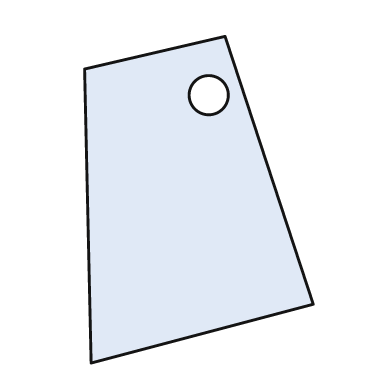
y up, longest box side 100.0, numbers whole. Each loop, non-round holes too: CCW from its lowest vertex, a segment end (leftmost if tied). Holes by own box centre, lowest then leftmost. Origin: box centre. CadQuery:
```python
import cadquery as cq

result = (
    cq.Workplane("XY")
    .moveTo(-33.0, -50.0)
    .lineTo(35.0, -32.0)
    .lineTo(8.0, 50.0)
    .lineTo(-35.0, 40.0)
    .close()
    .moveTo(3.0, 32.0)
    .circle(6.0)
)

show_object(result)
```